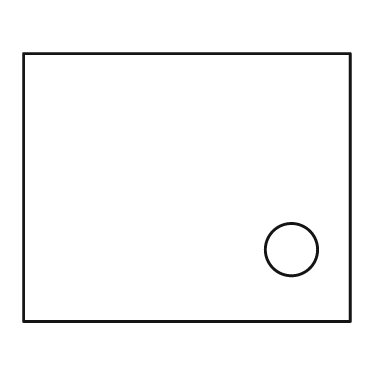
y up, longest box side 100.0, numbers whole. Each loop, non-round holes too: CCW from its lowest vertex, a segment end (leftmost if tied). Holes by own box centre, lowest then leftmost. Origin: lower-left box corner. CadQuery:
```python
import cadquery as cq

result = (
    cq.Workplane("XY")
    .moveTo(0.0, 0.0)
    .lineTo(100.0, 0.0)
    .lineTo(100.0, 82.0)
    .lineTo(0.0, 82.0)
    .close()
    .moveTo(82.0, 22.0)
    .circle(8.0)
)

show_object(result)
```